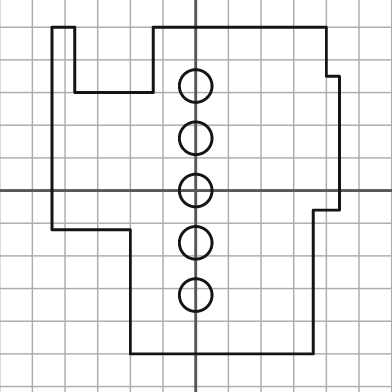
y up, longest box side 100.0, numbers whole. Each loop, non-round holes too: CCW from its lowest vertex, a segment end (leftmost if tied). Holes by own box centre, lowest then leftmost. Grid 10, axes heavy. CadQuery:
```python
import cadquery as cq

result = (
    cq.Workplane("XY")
    .moveTo(-20.0, -50.0)
    .lineTo(36.0, -50.0)
    .lineTo(36.0, -6.0)
    .lineTo(44.0, -6.0)
    .lineTo(44.0, 35.0)
    .lineTo(40.0, 35.0)
    .lineTo(40.0, 50.0)
    .lineTo(-13.0, 50.0)
    .lineTo(-13.0, 30.0)
    .lineTo(-37.0, 30.0)
    .lineTo(-37.0, 50.0)
    .lineTo(-44.0, 50.0)
    .lineTo(-44.0, -12.0)
    .lineTo(-20.0, -12.0)
    .close()
    .moveTo(0.0, -32.0)
    .circle(5.0)
    .moveTo(0.0, -16.0)
    .circle(5.0)
    .moveTo(0.0, 0.0)
    .circle(5.0)
    .moveTo(0.0, 16.0)
    .circle(5.0)
    .moveTo(0.0, 32.0)
    .circle(5.0)
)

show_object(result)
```